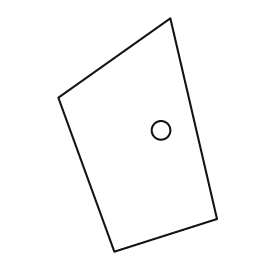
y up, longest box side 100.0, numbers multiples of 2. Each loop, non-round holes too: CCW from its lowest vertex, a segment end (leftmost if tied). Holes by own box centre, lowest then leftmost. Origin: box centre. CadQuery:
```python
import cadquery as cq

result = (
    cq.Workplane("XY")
    .moveTo(-10.0, -50.0)
    .lineTo(34.0, -36.0)
    .lineTo(14.0, 50.0)
    .lineTo(-34.0, 16.0)
    .close()
    .moveTo(10.0, 2.0)
    .circle(4.0)
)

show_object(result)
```